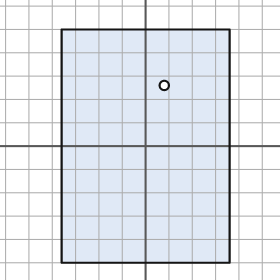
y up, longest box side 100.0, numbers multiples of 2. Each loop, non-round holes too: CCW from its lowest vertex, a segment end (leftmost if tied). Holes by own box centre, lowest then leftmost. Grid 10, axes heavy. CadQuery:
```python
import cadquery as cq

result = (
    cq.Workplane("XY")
    .moveTo(-36.0, -50.0)
    .lineTo(36.0, -50.0)
    .lineTo(36.0, 50.0)
    .lineTo(-36.0, 50.0)
    .close()
    .moveTo(8.0, 26.0)
    .circle(2.0)
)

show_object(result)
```